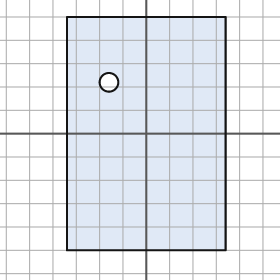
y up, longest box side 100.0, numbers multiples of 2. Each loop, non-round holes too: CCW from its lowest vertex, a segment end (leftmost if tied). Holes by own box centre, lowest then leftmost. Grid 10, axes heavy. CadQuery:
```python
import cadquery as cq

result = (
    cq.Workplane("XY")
    .moveTo(-34.0, -50.0)
    .lineTo(34.0, -50.0)
    .lineTo(34.0, 50.0)
    .lineTo(-34.0, 50.0)
    .close()
    .moveTo(-16.0, 22.0)
    .circle(4.0)
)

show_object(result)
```